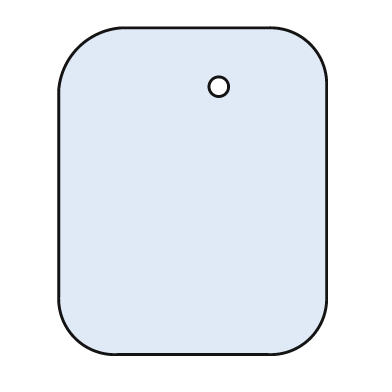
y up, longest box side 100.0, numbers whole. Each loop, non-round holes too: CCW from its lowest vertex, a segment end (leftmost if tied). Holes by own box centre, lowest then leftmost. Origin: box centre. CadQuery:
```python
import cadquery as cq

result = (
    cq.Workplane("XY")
    .moveTo(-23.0, -50.0)
    .lineTo(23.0, -50.0)
    .threePointArc((36.0, -45.0), (41.0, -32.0))
    .lineTo(41.0, 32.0)
    .threePointArc((36.0, 45.0), (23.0, 50.0))
    .lineTo(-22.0, 50.0)
    .threePointArc((-35.0, 44.0), (-41.0, 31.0))
    .lineTo(-41.0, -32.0)
    .threePointArc((-36.0, -45.0), (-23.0, -50.0))
    .close()
    .moveTo(8.0, 32.0)
    .circle(3.0)
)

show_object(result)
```